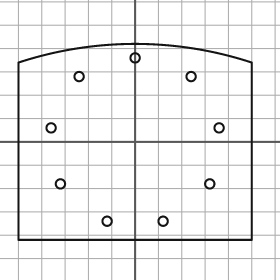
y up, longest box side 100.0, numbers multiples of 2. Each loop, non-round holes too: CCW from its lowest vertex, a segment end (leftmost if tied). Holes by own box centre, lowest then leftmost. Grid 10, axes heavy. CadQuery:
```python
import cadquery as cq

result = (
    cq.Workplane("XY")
    .moveTo(-50.0, -42.0)
    .lineTo(50.0, -42.0)
    .lineTo(50.0, 34.0)
    .threePointArc((0.0, 42.0), (-50.0, 34.0))
    .close()
    .moveTo(-12.0, -34.0)
    .circle(2.0)
    .moveTo(12.0, -34.0)
    .circle(2.0)
    .moveTo(-32.0, -18.0)
    .circle(2.0)
    .moveTo(32.0, -18.0)
    .circle(2.0)
    .moveTo(-36.0, 6.0)
    .circle(2.0)
    .moveTo(36.0, 6.0)
    .circle(2.0)
    .moveTo(-24.0, 28.0)
    .circle(2.0)
    .moveTo(24.0, 28.0)
    .circle(2.0)
    .moveTo(0.0, 36.0)
    .circle(2.0)
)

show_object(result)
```